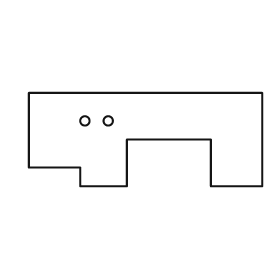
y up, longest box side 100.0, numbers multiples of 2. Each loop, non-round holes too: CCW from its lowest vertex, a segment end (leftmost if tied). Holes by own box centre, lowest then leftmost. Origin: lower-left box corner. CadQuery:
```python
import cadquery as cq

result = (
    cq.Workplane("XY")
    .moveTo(22.0, 0.0)
    .lineTo(42.0, 0.0)
    .lineTo(42.0, 20.0)
    .lineTo(78.0, 20.0)
    .lineTo(78.0, 0.0)
    .lineTo(100.0, 0.0)
    .lineTo(100.0, 40.0)
    .lineTo(0.0, 40.0)
    .lineTo(0.0, 8.0)
    .lineTo(22.0, 8.0)
    .close()
    .moveTo(24.0, 28.0)
    .circle(2.0)
    .moveTo(34.0, 28.0)
    .circle(2.0)
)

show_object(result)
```